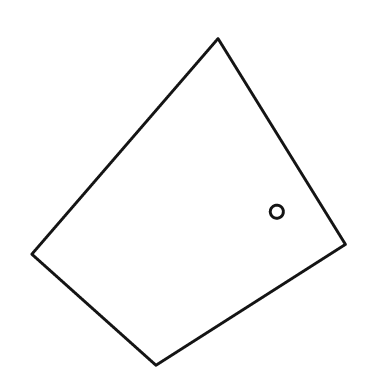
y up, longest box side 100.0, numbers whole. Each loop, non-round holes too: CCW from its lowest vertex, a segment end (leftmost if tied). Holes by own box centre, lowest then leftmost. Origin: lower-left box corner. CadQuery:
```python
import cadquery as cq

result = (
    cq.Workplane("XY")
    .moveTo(38.0, 0.0)
    .lineTo(96.0, 37.0)
    .lineTo(57.0, 100.0)
    .lineTo(0.0, 34.0)
    .close()
    .moveTo(75.0, 47.0)
    .circle(2.0)
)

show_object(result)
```